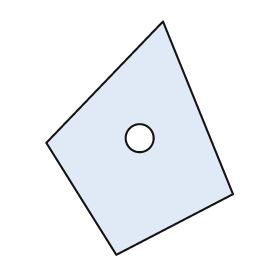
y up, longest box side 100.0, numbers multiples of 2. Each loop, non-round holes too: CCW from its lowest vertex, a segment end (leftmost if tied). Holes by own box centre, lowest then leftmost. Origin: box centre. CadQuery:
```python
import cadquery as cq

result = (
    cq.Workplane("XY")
    .moveTo(-10.0, -50.0)
    .lineTo(40.0, -24.0)
    .lineTo(10.0, 50.0)
    .lineTo(-40.0, -2.0)
    .close()
    .moveTo(0.0, 0.0)
    .circle(6.0)
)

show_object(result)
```